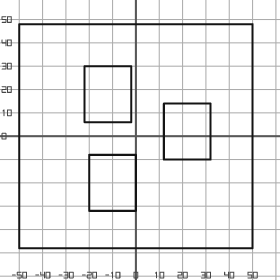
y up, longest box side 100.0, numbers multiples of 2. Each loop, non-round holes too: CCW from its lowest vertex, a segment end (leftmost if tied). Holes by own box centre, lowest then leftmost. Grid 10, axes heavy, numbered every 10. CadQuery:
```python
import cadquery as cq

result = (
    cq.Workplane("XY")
    .moveTo(-50.0, -48.0)
    .lineTo(50.0, -48.0)
    .lineTo(50.0, 48.0)
    .lineTo(-50.0, 48.0)
    .close()
    .moveTo(-20.0, -32.0)
    .lineTo(0.0, -32.0)
    .lineTo(0.0, -8.0)
    .lineTo(-20.0, -8.0)
    .close()
    .moveTo(12.0, -10.0)
    .lineTo(32.0, -10.0)
    .lineTo(32.0, 14.0)
    .lineTo(12.0, 14.0)
    .close()
    .moveTo(-22.0, 6.0)
    .lineTo(-2.0, 6.0)
    .lineTo(-2.0, 30.0)
    .lineTo(-22.0, 30.0)
    .close()
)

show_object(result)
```